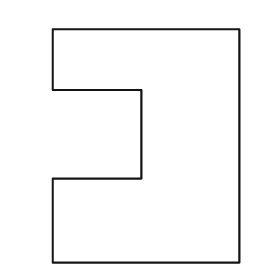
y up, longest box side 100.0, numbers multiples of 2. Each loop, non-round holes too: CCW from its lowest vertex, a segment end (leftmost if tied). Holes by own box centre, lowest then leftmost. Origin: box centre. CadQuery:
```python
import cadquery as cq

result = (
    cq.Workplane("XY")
    .moveTo(-40.0, -50.0)
    .lineTo(40.0, -50.0)
    .lineTo(40.0, 50.0)
    .lineTo(-40.0, 50.0)
    .lineTo(-40.0, 24.0)
    .lineTo(-2.0, 24.0)
    .lineTo(-2.0, -14.0)
    .lineTo(-40.0, -14.0)
    .close()
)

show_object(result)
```